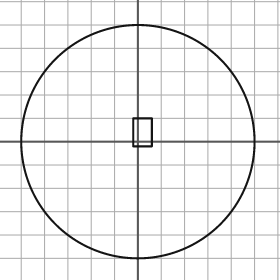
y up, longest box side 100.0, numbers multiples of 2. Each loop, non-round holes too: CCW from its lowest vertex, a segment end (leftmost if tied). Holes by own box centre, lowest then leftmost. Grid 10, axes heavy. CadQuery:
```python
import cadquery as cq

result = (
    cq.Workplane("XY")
    .moveTo(0.0, 0.0)
    .circle(50.0)
    .moveTo(-2.0, -2.0)
    .lineTo(6.0, -2.0)
    .lineTo(6.0, 10.0)
    .lineTo(-2.0, 10.0)
    .close()
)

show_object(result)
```